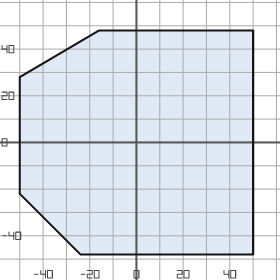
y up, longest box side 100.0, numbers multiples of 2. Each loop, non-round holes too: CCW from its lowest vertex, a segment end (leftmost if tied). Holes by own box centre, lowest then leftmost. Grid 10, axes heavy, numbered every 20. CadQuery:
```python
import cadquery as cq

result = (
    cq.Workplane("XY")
    .moveTo(-24.0, -48.0)
    .lineTo(50.0, -48.0)
    .lineTo(50.0, 48.0)
    .lineTo(-16.0, 48.0)
    .lineTo(-50.0, 28.0)
    .lineTo(-50.0, -22.0)
    .close()
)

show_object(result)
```